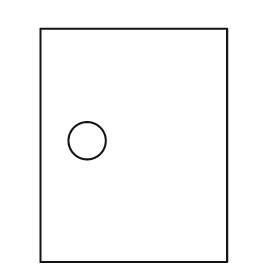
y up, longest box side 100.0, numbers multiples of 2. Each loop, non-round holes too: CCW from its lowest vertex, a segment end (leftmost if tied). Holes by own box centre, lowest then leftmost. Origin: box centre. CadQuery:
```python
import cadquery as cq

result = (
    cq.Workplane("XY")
    .moveTo(-40.0, -50.0)
    .lineTo(40.0, -50.0)
    .lineTo(40.0, 50.0)
    .lineTo(-40.0, 50.0)
    .close()
    .moveTo(-20.0, 2.0)
    .circle(8.0)
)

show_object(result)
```